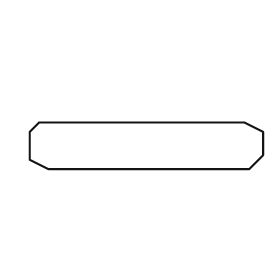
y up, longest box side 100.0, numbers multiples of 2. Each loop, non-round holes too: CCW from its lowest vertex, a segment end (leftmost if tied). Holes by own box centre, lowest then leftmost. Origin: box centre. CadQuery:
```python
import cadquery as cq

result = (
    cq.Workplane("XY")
    .moveTo(-42.0, -10.0)
    .lineTo(44.0, -10.0)
    .lineTo(50.0, -4.0)
    .lineTo(50.0, 6.0)
    .lineTo(42.0, 10.0)
    .lineTo(-46.0, 10.0)
    .lineTo(-50.0, 6.0)
    .lineTo(-50.0, -6.0)
    .close()
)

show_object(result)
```